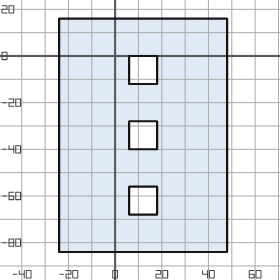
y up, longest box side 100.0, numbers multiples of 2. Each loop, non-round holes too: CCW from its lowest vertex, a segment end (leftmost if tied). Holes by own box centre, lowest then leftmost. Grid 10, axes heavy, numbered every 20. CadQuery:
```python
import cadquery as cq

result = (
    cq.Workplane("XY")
    .moveTo(-24.0, -84.0)
    .lineTo(48.0, -84.0)
    .lineTo(48.0, 16.0)
    .lineTo(-24.0, 16.0)
    .close()
    .moveTo(6.0, -68.0)
    .lineTo(18.0, -68.0)
    .lineTo(18.0, -56.0)
    .lineTo(6.0, -56.0)
    .close()
    .moveTo(6.0, -40.0)
    .lineTo(18.0, -40.0)
    .lineTo(18.0, -28.0)
    .lineTo(6.0, -28.0)
    .close()
    .moveTo(6.0, -12.0)
    .lineTo(18.0, -12.0)
    .lineTo(18.0, 0.0)
    .lineTo(6.0, 0.0)
    .close()
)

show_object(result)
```